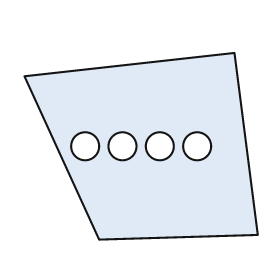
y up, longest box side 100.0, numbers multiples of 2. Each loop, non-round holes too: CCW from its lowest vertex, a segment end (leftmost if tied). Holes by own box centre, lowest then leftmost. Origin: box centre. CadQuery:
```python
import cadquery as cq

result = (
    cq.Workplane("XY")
    .moveTo(-18.0, -40.0)
    .lineTo(50.0, -38.0)
    .lineTo(40.0, 40.0)
    .lineTo(-50.0, 30.0)
    .close()
    .moveTo(-24.0, 0.0)
    .circle(6.0)
    .moveTo(-8.0, 0.0)
    .circle(6.0)
    .moveTo(8.0, 0.0)
    .circle(6.0)
    .moveTo(24.0, 0.0)
    .circle(6.0)
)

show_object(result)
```